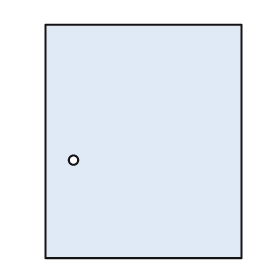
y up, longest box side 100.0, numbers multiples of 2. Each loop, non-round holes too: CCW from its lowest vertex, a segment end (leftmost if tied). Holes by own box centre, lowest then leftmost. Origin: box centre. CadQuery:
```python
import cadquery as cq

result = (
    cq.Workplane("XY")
    .moveTo(-42.0, -50.0)
    .lineTo(42.0, -50.0)
    .lineTo(42.0, 50.0)
    .lineTo(-42.0, 50.0)
    .close()
    .moveTo(-30.0, -8.0)
    .circle(2.0)
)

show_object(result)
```